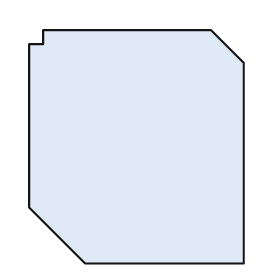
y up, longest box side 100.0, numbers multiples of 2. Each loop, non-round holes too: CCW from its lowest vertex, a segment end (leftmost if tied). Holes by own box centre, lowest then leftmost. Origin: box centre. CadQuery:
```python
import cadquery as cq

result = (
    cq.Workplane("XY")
    .moveTo(-22.0, -50.0)
    .lineTo(46.0, -50.0)
    .lineTo(46.0, 36.0)
    .lineTo(32.0, 50.0)
    .lineTo(-40.0, 50.0)
    .lineTo(-40.0, 44.0)
    .lineTo(-46.0, 44.0)
    .lineTo(-46.0, -26.0)
    .close()
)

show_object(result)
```